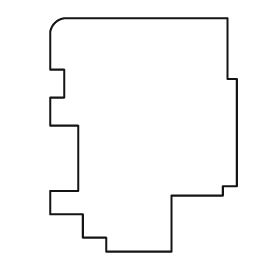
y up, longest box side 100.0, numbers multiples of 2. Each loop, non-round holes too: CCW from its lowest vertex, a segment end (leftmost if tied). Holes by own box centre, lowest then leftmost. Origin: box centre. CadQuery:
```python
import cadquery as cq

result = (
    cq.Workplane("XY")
    .moveTo(-16.0, -50.0)
    .lineTo(12.0, -50.0)
    .lineTo(12.0, -26.0)
    .lineTo(34.0, -26.0)
    .lineTo(34.0, -22.0)
    .lineTo(40.0, -22.0)
    .lineTo(40.0, 24.0)
    .lineTo(36.0, 24.0)
    .lineTo(36.0, 50.0)
    .lineTo(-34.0, 50.0)
    .threePointArc((-38.0, 48.0), (-40.0, 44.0))
    .lineTo(-40.0, 28.0)
    .lineTo(-34.0, 28.0)
    .lineTo(-34.0, 16.0)
    .lineTo(-40.0, 16.0)
    .lineTo(-40.0, 4.0)
    .lineTo(-28.0, 4.0)
    .lineTo(-28.0, -24.0)
    .lineTo(-40.0, -24.0)
    .lineTo(-40.0, -34.0)
    .lineTo(-26.0, -34.0)
    .lineTo(-26.0, -44.0)
    .lineTo(-16.0, -44.0)
    .close()
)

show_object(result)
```